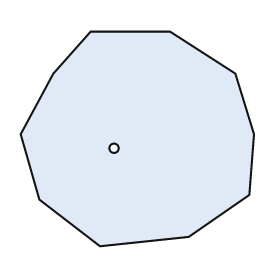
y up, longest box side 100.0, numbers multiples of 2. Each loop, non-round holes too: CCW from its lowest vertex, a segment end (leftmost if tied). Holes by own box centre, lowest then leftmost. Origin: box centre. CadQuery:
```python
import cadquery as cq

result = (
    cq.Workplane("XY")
    .moveTo(-16.0, -46.0)
    .lineTo(22.0, -42.0)
    .lineTo(48.0, -24.0)
    .lineTo(50.0, 2.0)
    .lineTo(42.0, 28.0)
    .lineTo(14.0, 46.0)
    .lineTo(-20.0, 46.0)
    .lineTo(-36.0, 28.0)
    .lineTo(-50.0, 2.0)
    .lineTo(-42.0, -26.0)
    .close()
    .moveTo(-10.0, -4.0)
    .circle(2.0)
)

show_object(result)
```